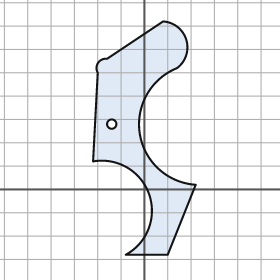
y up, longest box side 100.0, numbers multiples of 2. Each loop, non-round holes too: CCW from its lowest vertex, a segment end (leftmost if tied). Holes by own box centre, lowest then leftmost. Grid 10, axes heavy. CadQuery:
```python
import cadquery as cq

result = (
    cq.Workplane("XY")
    .moveTo(-8.0, -28.0)
    .lineTo(10.0, -28.0)
    .lineTo(22.0, 2.0)
    .threePointArc((-2.0, 24.0), (14.0, 52.0))
    .threePointArc((18.0, 64.0), (8.0, 72.0))
    .lineTo(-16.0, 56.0)
    .threePointArc((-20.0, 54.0), (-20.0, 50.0))
    .lineTo(-22.0, 12.0)
    .threePointArc((2.0, -2.0), (-8.0, -28.0))
    .close()
    .moveTo(-14.0, 28.0)
    .circle(2.0)
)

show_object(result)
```